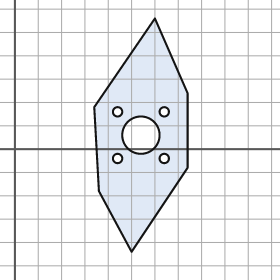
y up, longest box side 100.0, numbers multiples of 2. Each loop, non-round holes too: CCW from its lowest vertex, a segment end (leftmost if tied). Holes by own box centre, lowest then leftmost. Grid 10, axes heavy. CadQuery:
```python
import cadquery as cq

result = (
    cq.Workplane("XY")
    .moveTo(50.0, -44.0)
    .lineTo(74.0, -8.0)
    .lineTo(74.0, 24.0)
    .lineTo(60.0, 56.0)
    .lineTo(34.0, 18.0)
    .lineTo(36.0, -18.0)
    .close()
    .moveTo(44.0, -4.0)
    .circle(2.0)
    .moveTo(64.0, -4.0)
    .circle(2.0)
    .moveTo(54.0, 6.0)
    .circle(8.0)
    .moveTo(44.0, 16.0)
    .circle(2.0)
    .moveTo(64.0, 16.0)
    .circle(2.0)
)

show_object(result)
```